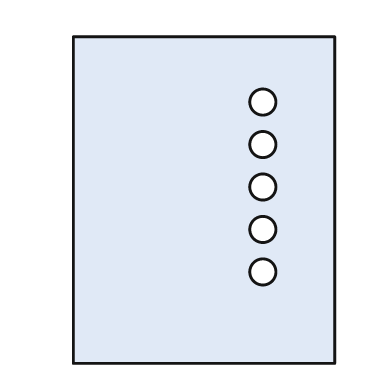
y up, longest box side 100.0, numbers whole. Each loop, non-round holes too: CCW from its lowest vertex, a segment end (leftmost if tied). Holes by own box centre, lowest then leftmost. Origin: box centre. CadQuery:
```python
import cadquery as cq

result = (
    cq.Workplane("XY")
    .moveTo(-40.0, -50.0)
    .lineTo(40.0, -50.0)
    .lineTo(40.0, 50.0)
    .lineTo(-40.0, 50.0)
    .close()
    .moveTo(18.0, -22.0)
    .circle(4.0)
    .moveTo(18.0, -9.0)
    .circle(4.0)
    .moveTo(18.0, 4.0)
    .circle(4.0)
    .moveTo(18.0, 17.0)
    .circle(4.0)
    .moveTo(18.0, 30.0)
    .circle(4.0)
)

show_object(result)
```